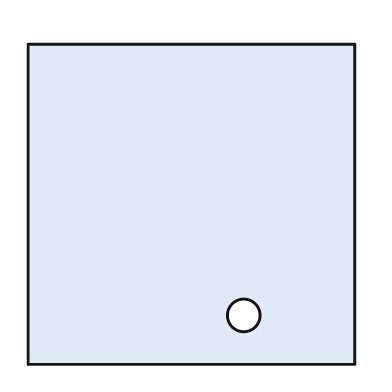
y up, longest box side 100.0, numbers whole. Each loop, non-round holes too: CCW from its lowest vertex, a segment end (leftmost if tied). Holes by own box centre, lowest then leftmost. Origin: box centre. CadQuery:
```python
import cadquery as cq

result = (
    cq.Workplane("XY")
    .moveTo(-50.0, -49.0)
    .lineTo(50.0, -49.0)
    .lineTo(50.0, 49.0)
    .lineTo(-50.0, 49.0)
    .close()
    .moveTo(16.0, -34.0)
    .circle(5.0)
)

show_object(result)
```